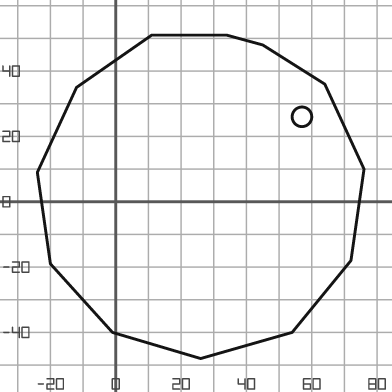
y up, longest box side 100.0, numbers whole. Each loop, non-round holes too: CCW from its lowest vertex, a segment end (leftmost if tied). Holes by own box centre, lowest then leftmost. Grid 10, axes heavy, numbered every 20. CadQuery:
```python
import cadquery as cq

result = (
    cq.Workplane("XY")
    .moveTo(26.0, -48.0)
    .lineTo(54.0, -40.0)
    .lineTo(72.0, -18.0)
    .lineTo(76.0, 10.0)
    .lineTo(64.0, 36.0)
    .lineTo(45.0, 48.0)
    .lineTo(34.0, 51.0)
    .lineTo(11.0, 51.0)
    .lineTo(-12.0, 35.0)
    .lineTo(-24.0, 9.0)
    .lineTo(-20.0, -19.0)
    .lineTo(-1.0, -40.0)
    .close()
    .moveTo(57.0, 26.0)
    .circle(3.0)
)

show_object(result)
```